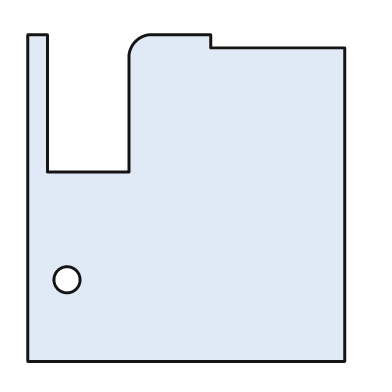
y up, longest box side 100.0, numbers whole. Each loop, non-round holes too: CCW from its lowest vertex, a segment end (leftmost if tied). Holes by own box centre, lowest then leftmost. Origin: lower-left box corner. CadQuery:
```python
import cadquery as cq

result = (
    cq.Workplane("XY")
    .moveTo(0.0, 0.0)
    .lineTo(97.0, 0.0)
    .lineTo(97.0, 96.0)
    .lineTo(56.0, 96.0)
    .lineTo(56.0, 100.0)
    .lineTo(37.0, 100.0)
    .threePointArc((33.0, 98.0), (31.0, 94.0))
    .lineTo(31.0, 58.0)
    .lineTo(6.0, 58.0)
    .lineTo(6.0, 100.0)
    .lineTo(0.0, 100.0)
    .close()
    .moveTo(12.0, 25.0)
    .circle(4.0)
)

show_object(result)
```